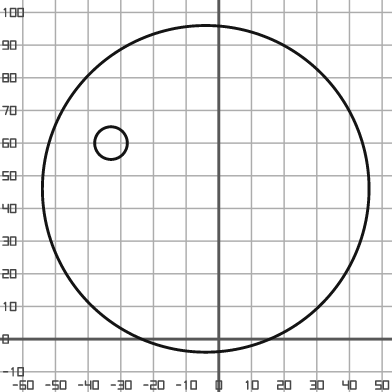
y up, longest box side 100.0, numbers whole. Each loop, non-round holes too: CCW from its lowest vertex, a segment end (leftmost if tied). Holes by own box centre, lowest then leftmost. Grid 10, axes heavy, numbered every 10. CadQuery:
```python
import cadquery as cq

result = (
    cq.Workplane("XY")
    .moveTo(-4.0, 46.0)
    .circle(50.0)
    .moveTo(-33.0, 60.0)
    .circle(5.0)
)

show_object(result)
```